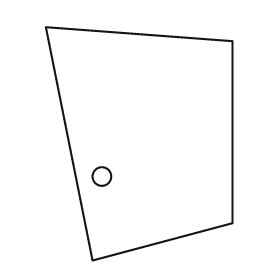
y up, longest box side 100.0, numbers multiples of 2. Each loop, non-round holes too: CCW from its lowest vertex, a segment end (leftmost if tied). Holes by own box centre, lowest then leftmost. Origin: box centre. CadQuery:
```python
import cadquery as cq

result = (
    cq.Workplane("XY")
    .moveTo(-20.0, -50.0)
    .lineTo(40.0, -34.0)
    .lineTo(40.0, 44.0)
    .lineTo(-40.0, 50.0)
    .close()
    .moveTo(-16.0, -14.0)
    .circle(4.0)
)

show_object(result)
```